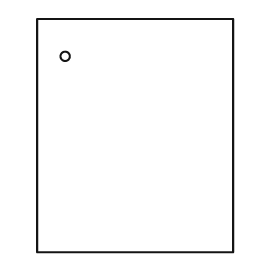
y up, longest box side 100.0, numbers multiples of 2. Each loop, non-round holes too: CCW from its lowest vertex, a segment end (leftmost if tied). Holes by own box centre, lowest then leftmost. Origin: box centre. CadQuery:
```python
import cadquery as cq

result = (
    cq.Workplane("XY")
    .moveTo(-42.0, -50.0)
    .lineTo(42.0, -50.0)
    .lineTo(42.0, 50.0)
    .lineTo(-42.0, 50.0)
    .close()
    .moveTo(-30.0, 34.0)
    .circle(2.0)
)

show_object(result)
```